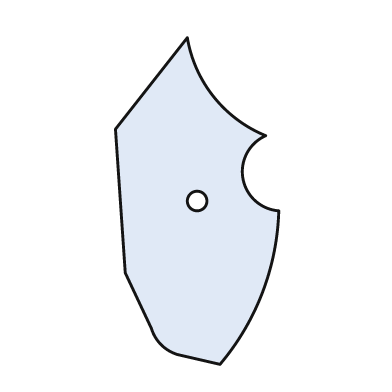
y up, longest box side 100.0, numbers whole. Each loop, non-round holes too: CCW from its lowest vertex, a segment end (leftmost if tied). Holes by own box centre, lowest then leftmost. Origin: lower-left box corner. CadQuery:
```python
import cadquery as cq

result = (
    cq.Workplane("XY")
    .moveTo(32.0, 0.0)
    .threePointArc((45.0, 22.0), (50.0, 47.0))
    .threePointArc((39.0, 57.0), (46.0, 70.0))
    .threePointArc((30.0, 82.0), (22.0, 100.0))
    .lineTo(0.0, 72.0)
    .lineTo(3.0, 28.0)
    .lineTo(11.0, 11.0)
    .threePointArc((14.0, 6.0), (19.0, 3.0))
    .close()
    .moveTo(25.0, 50.0)
    .circle(3.0)
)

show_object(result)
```